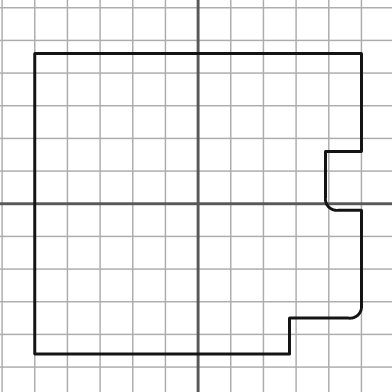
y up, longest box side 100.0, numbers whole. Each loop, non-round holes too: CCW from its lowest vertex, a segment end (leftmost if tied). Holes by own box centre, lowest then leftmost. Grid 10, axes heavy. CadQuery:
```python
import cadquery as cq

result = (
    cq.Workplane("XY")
    .moveTo(-50.0, -46.0)
    .lineTo(28.0, -46.0)
    .lineTo(28.0, -35.0)
    .lineTo(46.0, -35.0)
    .threePointArc((49.0, -34.0), (50.0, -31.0))
    .lineTo(50.0, -2.0)
    .lineTo(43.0, -2.0)
    .threePointArc((40.0, -1.0), (39.0, 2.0))
    .lineTo(39.0, 16.0)
    .lineTo(50.0, 16.0)
    .lineTo(50.0, 46.0)
    .lineTo(-50.0, 46.0)
    .close()
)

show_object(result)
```